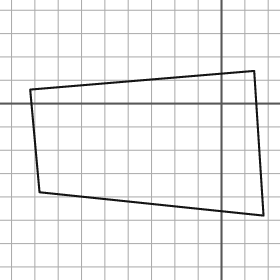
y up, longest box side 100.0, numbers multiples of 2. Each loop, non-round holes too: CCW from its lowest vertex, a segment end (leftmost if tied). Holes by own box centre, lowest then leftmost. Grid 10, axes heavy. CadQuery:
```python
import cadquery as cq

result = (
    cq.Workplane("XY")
    .moveTo(18.0, -48.0)
    .lineTo(14.0, 14.0)
    .lineTo(-82.0, 6.0)
    .lineTo(-78.0, -38.0)
    .close()
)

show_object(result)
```